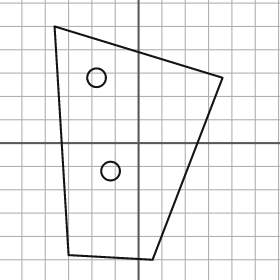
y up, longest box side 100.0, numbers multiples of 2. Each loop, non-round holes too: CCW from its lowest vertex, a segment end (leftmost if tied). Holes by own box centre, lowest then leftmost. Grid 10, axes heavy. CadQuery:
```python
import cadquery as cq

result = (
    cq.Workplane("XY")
    .moveTo(6.0, -50.0)
    .lineTo(36.0, 28.0)
    .lineTo(-36.0, 50.0)
    .lineTo(-30.0, -48.0)
    .close()
    .moveTo(-12.0, -12.0)
    .circle(4.0)
    .moveTo(-18.0, 28.0)
    .circle(4.0)
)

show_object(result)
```